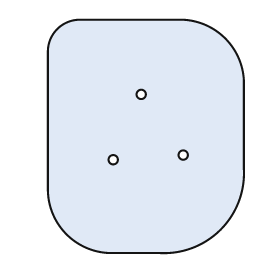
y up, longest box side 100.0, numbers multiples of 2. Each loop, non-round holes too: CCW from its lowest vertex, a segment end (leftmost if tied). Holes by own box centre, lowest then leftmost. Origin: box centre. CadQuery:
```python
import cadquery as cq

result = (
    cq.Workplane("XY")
    .moveTo(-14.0, -50.0)
    .lineTo(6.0, -50.0)
    .threePointArc((32.0, -40.0), (42.0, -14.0))
    .lineTo(42.0, 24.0)
    .threePointArc((34.0, 42.0), (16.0, 50.0))
    .lineTo(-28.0, 50.0)
    .threePointArc((-38.0, 46.0), (-42.0, 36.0))
    .lineTo(-42.0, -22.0)
    .threePointArc((-34.0, -42.0), (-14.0, -50.0))
    .close()
    .moveTo(-14.0, -10.0)
    .circle(2.0)
    .moveTo(16.0, -8.0)
    .circle(2.0)
    .moveTo(-2.0, 18.0)
    .circle(2.0)
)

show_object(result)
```